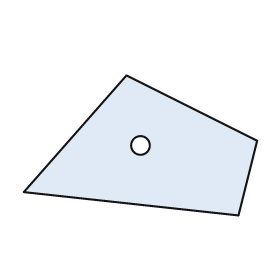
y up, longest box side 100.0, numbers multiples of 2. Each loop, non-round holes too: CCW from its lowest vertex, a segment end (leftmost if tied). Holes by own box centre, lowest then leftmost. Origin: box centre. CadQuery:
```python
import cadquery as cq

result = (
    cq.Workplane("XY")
    .moveTo(42.0, -30.0)
    .lineTo(50.0, 2.0)
    .lineTo(-6.0, 30.0)
    .lineTo(-50.0, -20.0)
    .close()
    .moveTo(0.0, 0.0)
    .circle(4.0)
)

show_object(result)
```